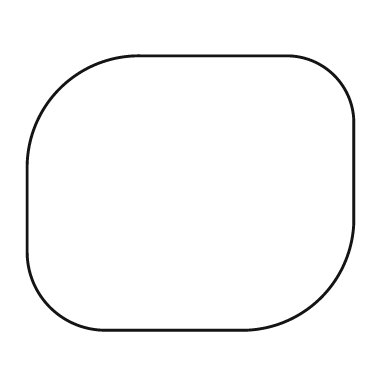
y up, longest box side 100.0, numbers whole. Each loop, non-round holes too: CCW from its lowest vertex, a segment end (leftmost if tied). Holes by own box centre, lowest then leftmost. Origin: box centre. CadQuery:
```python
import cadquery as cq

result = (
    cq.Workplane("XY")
    .moveTo(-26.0, -42.0)
    .lineTo(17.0, -42.0)
    .threePointArc((40.0, -32.0), (50.0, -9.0))
    .lineTo(50.0, 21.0)
    .threePointArc((44.0, 36.0), (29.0, 42.0))
    .lineTo(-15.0, 42.0)
    .threePointArc((-40.0, 32.0), (-50.0, 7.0))
    .lineTo(-50.0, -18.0)
    .threePointArc((-43.0, -35.0), (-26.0, -42.0))
    .close()
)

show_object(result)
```